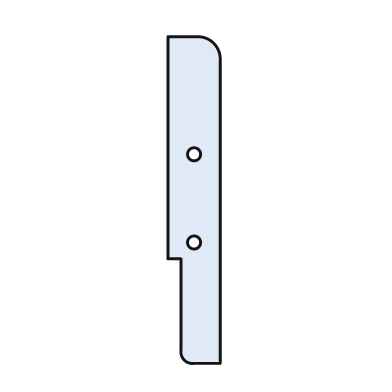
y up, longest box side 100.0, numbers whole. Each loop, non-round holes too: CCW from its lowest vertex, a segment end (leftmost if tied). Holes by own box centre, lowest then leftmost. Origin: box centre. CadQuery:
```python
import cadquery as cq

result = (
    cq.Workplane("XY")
    .moveTo(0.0, -50.0)
    .lineTo(8.0, -50.0)
    .lineTo(8.0, 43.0)
    .threePointArc((6.0, 48.0), (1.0, 50.0))
    .lineTo(-8.0, 50.0)
    .lineTo(-8.0, -18.0)
    .lineTo(-4.0, -18.0)
    .lineTo(-4.0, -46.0)
    .threePointArc((-3.0, -49.0), (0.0, -50.0))
    .close()
    .moveTo(0.0, -13.0)
    .circle(2.0)
    .moveTo(0.0, 14.0)
    .circle(2.0)
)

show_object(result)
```